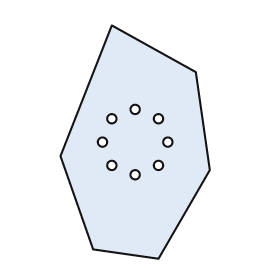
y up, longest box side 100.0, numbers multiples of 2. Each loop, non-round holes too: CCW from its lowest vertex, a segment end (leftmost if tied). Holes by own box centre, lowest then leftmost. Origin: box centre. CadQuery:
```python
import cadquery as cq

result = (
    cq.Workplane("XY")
    .moveTo(10.0, -50.0)
    .lineTo(32.0, -12.0)
    .lineTo(26.0, 30.0)
    .lineTo(-10.0, 50.0)
    .lineTo(-32.0, -6.0)
    .lineTo(-18.0, -46.0)
    .close()
    .moveTo(0.0, -14.0)
    .circle(2.0)
    .moveTo(-10.0, -10.0)
    .circle(2.0)
    .moveTo(10.0, -10.0)
    .circle(2.0)
    .moveTo(-14.0, 0.0)
    .circle(2.0)
    .moveTo(14.0, 0.0)
    .circle(2.0)
    .moveTo(-10.0, 10.0)
    .circle(2.0)
    .moveTo(10.0, 10.0)
    .circle(2.0)
    .moveTo(0.0, 14.0)
    .circle(2.0)
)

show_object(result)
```